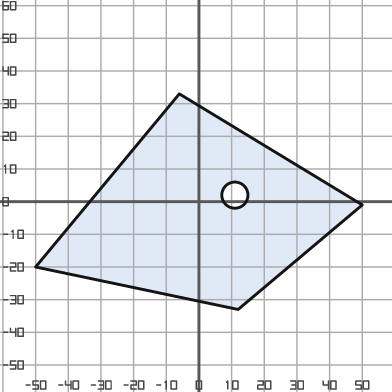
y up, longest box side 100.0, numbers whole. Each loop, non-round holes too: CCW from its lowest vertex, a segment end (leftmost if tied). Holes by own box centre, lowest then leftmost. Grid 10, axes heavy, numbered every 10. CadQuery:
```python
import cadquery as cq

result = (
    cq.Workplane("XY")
    .moveTo(12.0, -33.0)
    .lineTo(50.0, -1.0)
    .lineTo(-6.0, 33.0)
    .lineTo(-50.0, -20.0)
    .close()
    .moveTo(11.0, 2.0)
    .circle(4.0)
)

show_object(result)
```